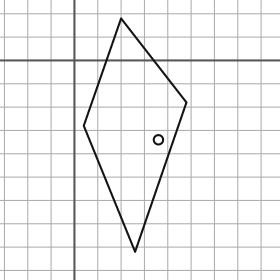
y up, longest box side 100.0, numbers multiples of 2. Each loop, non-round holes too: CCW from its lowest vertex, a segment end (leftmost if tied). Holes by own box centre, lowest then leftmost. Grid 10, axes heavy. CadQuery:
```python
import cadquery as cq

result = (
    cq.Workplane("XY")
    .moveTo(26.0, -82.0)
    .lineTo(48.0, -18.0)
    .lineTo(20.0, 18.0)
    .lineTo(4.0, -28.0)
    .close()
    .moveTo(36.0, -34.0)
    .circle(2.0)
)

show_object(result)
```